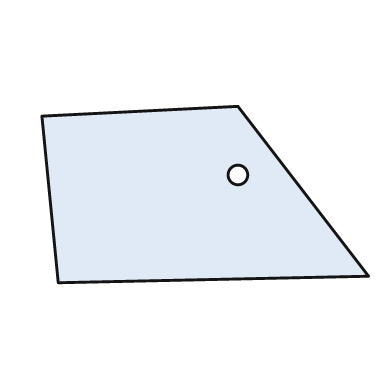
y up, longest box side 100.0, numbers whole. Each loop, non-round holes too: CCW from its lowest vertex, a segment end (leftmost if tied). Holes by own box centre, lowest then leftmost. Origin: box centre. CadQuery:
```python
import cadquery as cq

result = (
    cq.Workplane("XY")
    .moveTo(-45.0, -27.0)
    .lineTo(50.0, -25.0)
    .lineTo(10.0, 27.0)
    .lineTo(-50.0, 24.0)
    .close()
    .moveTo(10.0, 6.0)
    .circle(3.0)
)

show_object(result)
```